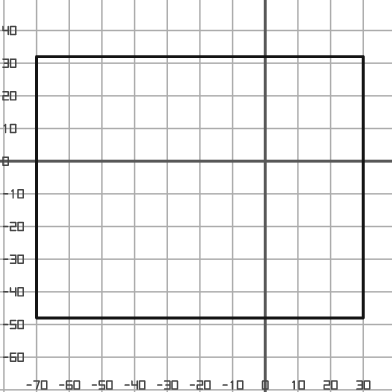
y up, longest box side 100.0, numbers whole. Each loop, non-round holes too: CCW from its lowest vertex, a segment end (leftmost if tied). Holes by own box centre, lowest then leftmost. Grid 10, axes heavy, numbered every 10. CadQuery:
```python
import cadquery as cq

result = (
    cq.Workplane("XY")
    .moveTo(-70.0, -48.0)
    .lineTo(30.0, -48.0)
    .lineTo(30.0, 32.0)
    .lineTo(-70.0, 32.0)
    .close()
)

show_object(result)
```